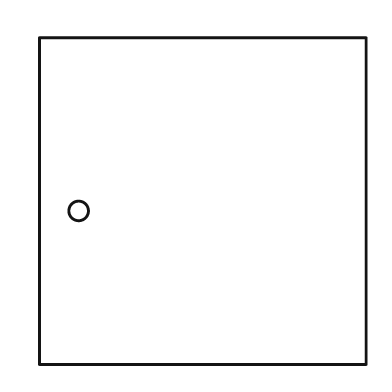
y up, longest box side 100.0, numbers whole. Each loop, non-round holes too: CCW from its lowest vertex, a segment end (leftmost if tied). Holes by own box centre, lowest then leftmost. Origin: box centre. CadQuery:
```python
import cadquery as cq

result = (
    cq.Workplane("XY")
    .moveTo(-50.0, -50.0)
    .lineTo(50.0, -50.0)
    .lineTo(50.0, 50.0)
    .lineTo(-50.0, 50.0)
    .close()
    .moveTo(-38.0, -3.0)
    .circle(3.0)
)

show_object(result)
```